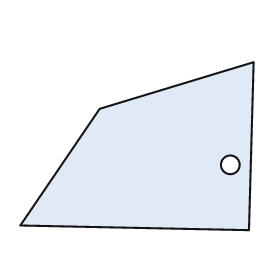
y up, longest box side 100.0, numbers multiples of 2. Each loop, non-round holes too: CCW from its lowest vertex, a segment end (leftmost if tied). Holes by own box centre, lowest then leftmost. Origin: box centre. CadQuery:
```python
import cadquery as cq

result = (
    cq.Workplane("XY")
    .moveTo(48.0, -36.0)
    .lineTo(50.0, 36.0)
    .lineTo(-16.0, 16.0)
    .lineTo(-50.0, -34.0)
    .close()
    .moveTo(40.0, -8.0)
    .circle(4.0)
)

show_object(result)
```